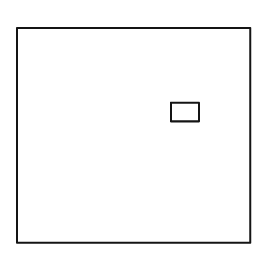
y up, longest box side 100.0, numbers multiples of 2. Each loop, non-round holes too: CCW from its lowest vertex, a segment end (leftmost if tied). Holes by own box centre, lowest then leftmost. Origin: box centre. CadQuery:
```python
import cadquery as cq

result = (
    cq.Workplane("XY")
    .moveTo(-50.0, -46.0)
    .lineTo(50.0, -46.0)
    .lineTo(50.0, 46.0)
    .lineTo(-50.0, 46.0)
    .close()
    .moveTo(16.0, 6.0)
    .lineTo(28.0, 6.0)
    .lineTo(28.0, 14.0)
    .lineTo(16.0, 14.0)
    .close()
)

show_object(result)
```